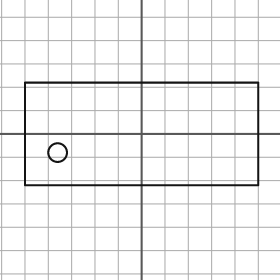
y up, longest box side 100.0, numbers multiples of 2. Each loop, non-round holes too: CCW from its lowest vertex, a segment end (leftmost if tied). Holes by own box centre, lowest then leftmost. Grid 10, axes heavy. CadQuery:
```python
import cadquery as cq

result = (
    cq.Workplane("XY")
    .moveTo(-50.0, -22.0)
    .lineTo(50.0, -22.0)
    .lineTo(50.0, 22.0)
    .lineTo(-50.0, 22.0)
    .close()
    .moveTo(-36.0, -8.0)
    .circle(4.0)
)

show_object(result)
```